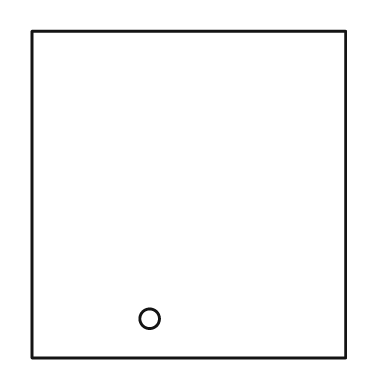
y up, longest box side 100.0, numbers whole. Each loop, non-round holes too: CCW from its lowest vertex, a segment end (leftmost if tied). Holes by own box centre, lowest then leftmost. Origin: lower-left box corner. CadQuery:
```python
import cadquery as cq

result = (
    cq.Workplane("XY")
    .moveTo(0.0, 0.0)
    .lineTo(96.0, 0.0)
    .lineTo(96.0, 100.0)
    .lineTo(0.0, 100.0)
    .close()
    .moveTo(36.0, 12.0)
    .circle(3.0)
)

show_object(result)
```